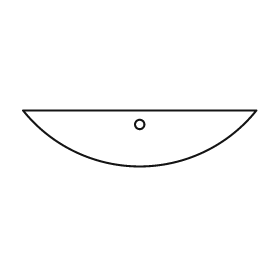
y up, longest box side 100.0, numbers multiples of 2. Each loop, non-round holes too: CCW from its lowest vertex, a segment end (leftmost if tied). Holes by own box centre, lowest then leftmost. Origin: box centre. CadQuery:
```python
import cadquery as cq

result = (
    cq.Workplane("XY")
    .moveTo(-50.0, 12.0)
    .threePointArc((0.0, -12.0), (50.0, 12.0))
    .close()
    .moveTo(0.0, 6.0)
    .circle(2.0)
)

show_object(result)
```